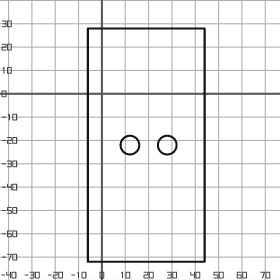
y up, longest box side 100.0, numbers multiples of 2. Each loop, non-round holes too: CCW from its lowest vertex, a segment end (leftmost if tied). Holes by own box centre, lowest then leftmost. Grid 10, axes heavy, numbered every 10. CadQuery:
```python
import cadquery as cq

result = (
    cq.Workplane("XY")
    .moveTo(-6.0, -72.0)
    .lineTo(44.0, -72.0)
    .lineTo(44.0, 28.0)
    .lineTo(-6.0, 28.0)
    .close()
    .moveTo(12.0, -22.0)
    .circle(4.0)
    .moveTo(28.0, -22.0)
    .circle(4.0)
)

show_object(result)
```